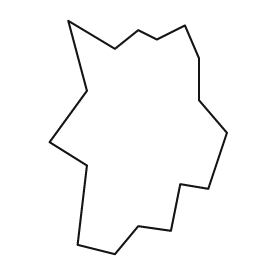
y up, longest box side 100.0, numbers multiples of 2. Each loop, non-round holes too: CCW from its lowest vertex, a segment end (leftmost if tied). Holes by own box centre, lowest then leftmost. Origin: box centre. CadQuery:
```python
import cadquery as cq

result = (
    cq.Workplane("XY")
    .moveTo(-10.0, -50.0)
    .lineTo(0.0, -38.0)
    .lineTo(14.0, -40.0)
    .lineTo(18.0, -20.0)
    .lineTo(30.0, -22.0)
    .lineTo(38.0, 2.0)
    .lineTo(26.0, 16.0)
    .lineTo(26.0, 34.0)
    .lineTo(20.0, 48.0)
    .lineTo(8.0, 42.0)
    .lineTo(0.0, 46.0)
    .lineTo(-10.0, 38.0)
    .lineTo(-30.0, 50.0)
    .lineTo(-22.0, 20.0)
    .lineTo(-38.0, -2.0)
    .lineTo(-22.0, -12.0)
    .lineTo(-26.0, -46.0)
    .close()
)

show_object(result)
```